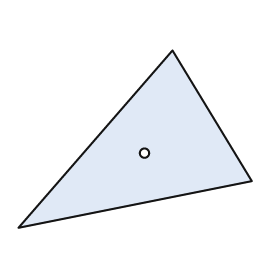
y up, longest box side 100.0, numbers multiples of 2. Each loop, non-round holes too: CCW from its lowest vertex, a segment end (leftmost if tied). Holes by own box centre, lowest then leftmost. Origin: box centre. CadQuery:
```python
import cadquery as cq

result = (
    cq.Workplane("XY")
    .moveTo(-50.0, -38.0)
    .lineTo(50.0, -18.0)
    .lineTo(16.0, 38.0)
    .close()
    .moveTo(4.0, -6.0)
    .circle(2.0)
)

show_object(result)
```